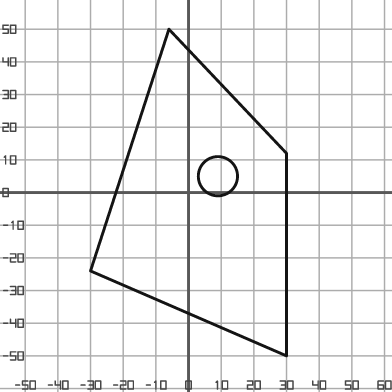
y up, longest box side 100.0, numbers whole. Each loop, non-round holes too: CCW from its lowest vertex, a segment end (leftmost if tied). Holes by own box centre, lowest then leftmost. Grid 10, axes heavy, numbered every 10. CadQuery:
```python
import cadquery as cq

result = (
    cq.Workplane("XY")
    .moveTo(30.0, -50.0)
    .lineTo(30.0, 12.0)
    .lineTo(-6.0, 50.0)
    .lineTo(-30.0, -24.0)
    .close()
    .moveTo(9.0, 5.0)
    .circle(6.0)
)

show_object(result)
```